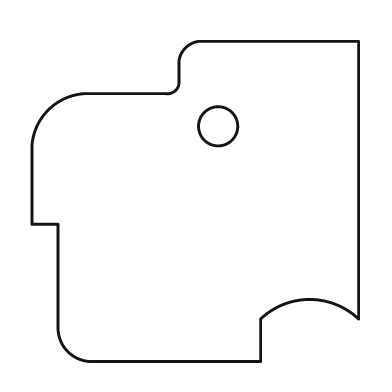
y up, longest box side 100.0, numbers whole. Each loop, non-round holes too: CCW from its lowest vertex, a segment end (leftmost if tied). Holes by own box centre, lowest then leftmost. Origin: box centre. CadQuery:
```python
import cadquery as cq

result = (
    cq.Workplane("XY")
    .moveTo(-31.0, -49.0)
    .lineTo(20.0, -49.0)
    .lineTo(20.0, -36.0)
    .threePointArc((35.0, -30.0), (50.0, -36.0))
    .lineTo(50.0, 49.0)
    .lineTo(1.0, 49.0)
    .threePointArc((-3.0, 47.0), (-5.0, 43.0))
    .lineTo(-5.0, 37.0)
    .threePointArc((-6.0, 34.0), (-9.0, 33.0))
    .lineTo(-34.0, 33.0)
    .threePointArc((-45.0, 28.0), (-50.0, 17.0))
    .lineTo(-50.0, -7.0)
    .lineTo(-42.0, -7.0)
    .lineTo(-42.0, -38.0)
    .threePointArc((-39.0, -46.0), (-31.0, -49.0))
    .close()
    .moveTo(7.0, 23.0)
    .circle(6.0)
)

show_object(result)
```